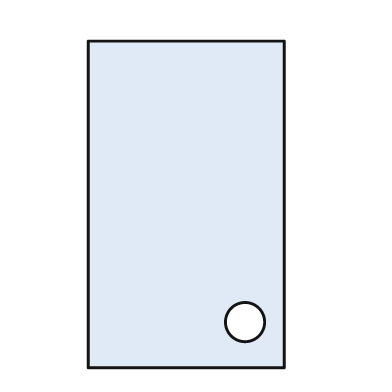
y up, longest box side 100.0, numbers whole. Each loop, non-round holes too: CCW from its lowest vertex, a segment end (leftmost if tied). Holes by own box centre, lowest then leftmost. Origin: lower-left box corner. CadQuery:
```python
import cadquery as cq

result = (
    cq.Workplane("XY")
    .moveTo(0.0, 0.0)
    .lineTo(60.0, 0.0)
    .lineTo(60.0, 100.0)
    .lineTo(0.0, 100.0)
    .close()
    .moveTo(48.0, 14.0)
    .circle(6.0)
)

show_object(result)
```